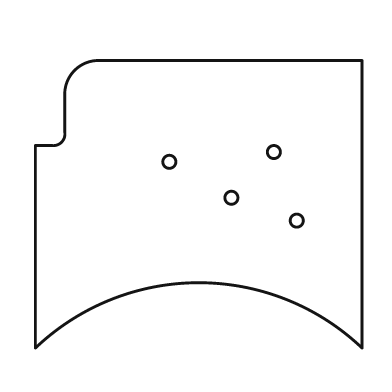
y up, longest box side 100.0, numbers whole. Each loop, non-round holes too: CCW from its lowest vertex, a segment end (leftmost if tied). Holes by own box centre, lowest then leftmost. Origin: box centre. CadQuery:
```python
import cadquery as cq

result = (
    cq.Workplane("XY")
    .moveTo(-50.0, -44.0)
    .threePointArc((0.0, -24.0), (50.0, -44.0))
    .lineTo(50.0, 44.0)
    .lineTo(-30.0, 44.0)
    .threePointArc((-38.0, 41.0), (-41.0, 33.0))
    .lineTo(-41.0, 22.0)
    .threePointArc((-42.0, 19.0), (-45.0, 18.0))
    .lineTo(-50.0, 18.0)
    .close()
    .moveTo(30.0, -5.0)
    .circle(2.0)
    .moveTo(10.0, 2.0)
    .circle(2.0)
    .moveTo(-9.0, 13.0)
    .circle(2.0)
    .moveTo(23.0, 16.0)
    .circle(2.0)
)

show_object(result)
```